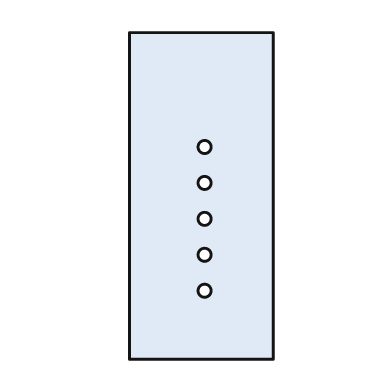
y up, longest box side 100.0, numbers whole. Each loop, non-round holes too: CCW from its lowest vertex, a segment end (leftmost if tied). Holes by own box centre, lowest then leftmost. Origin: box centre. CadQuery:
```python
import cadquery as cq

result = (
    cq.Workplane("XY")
    .moveTo(-22.0, -50.0)
    .lineTo(22.0, -50.0)
    .lineTo(22.0, 50.0)
    .lineTo(-22.0, 50.0)
    .close()
    .moveTo(1.0, -29.0)
    .circle(2.0)
    .moveTo(1.0, -18.0)
    .circle(2.0)
    .moveTo(1.0, -7.0)
    .circle(2.0)
    .moveTo(1.0, 4.0)
    .circle(2.0)
    .moveTo(1.0, 15.0)
    .circle(2.0)
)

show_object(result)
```